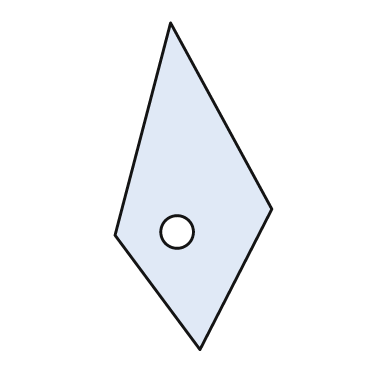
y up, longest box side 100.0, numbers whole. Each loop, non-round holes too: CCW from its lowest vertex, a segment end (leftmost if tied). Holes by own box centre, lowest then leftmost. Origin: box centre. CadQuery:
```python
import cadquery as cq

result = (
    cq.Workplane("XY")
    .moveTo(2.0, -50.0)
    .lineTo(24.0, -7.0)
    .lineTo(-7.0, 50.0)
    .lineTo(-24.0, -15.0)
    .close()
    .moveTo(-5.0, -14.0)
    .circle(5.0)
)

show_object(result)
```